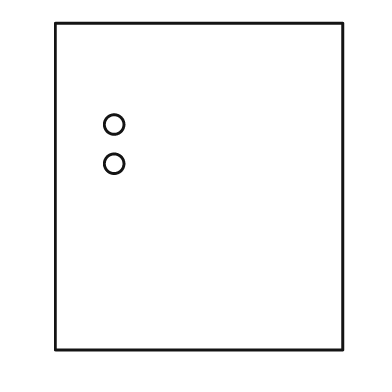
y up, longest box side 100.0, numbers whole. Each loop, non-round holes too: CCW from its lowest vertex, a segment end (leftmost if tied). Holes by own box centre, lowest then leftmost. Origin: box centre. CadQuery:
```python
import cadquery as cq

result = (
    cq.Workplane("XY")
    .moveTo(-44.0, -50.0)
    .lineTo(44.0, -50.0)
    .lineTo(44.0, 50.0)
    .lineTo(-44.0, 50.0)
    .close()
    .moveTo(-26.0, 7.0)
    .circle(3.0)
    .moveTo(-26.0, 19.0)
    .circle(3.0)
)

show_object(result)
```